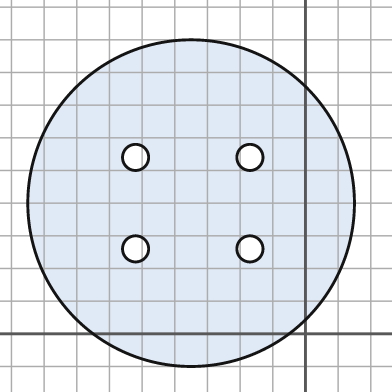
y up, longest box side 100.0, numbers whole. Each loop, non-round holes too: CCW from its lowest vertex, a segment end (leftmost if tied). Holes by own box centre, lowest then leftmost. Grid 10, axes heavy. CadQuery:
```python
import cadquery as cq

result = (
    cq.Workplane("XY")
    .moveTo(-35.0, 40.0)
    .circle(50.0)
    .moveTo(-52.0, 26.0)
    .circle(4.0)
    .moveTo(-17.0, 26.0)
    .circle(4.0)
    .moveTo(-52.0, 54.0)
    .circle(4.0)
    .moveTo(-17.0, 54.0)
    .circle(4.0)
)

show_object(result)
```